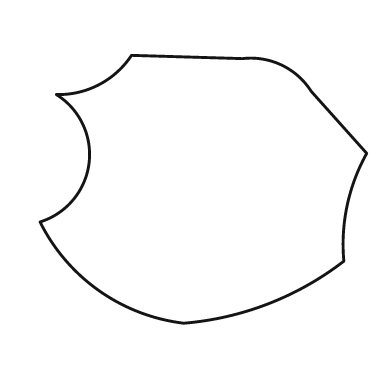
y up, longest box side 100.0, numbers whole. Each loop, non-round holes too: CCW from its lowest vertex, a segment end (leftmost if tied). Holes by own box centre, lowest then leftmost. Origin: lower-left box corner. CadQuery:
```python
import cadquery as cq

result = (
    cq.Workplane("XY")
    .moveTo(44.0, 0.0)
    .threePointArc((70.0, 6.0), (93.0, 19.0))
    .threePointArc((94.0, 36.0), (100.0, 52.0))
    .lineTo(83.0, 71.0)
    .threePointArc((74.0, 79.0), (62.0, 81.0))
    .lineTo(28.0, 82.0)
    .threePointArc((18.0, 73.0), (5.0, 70.0))
    .threePointArc((15.0, 49.0), (0.0, 31.0))
    .threePointArc((18.0, 10.0), (44.0, 0.0))
    .close()
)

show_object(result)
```